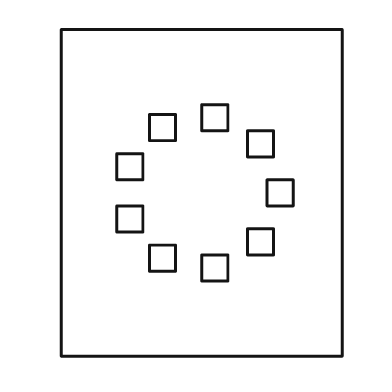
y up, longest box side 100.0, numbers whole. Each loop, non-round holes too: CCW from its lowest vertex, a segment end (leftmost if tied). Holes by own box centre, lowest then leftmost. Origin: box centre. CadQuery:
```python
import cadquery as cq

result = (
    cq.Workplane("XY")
    .moveTo(-43.0, -50.0)
    .lineTo(43.0, -50.0)
    .lineTo(43.0, 50.0)
    .lineTo(-43.0, 50.0)
    .close()
    .moveTo(0.0, -27.0)
    .lineTo(8.0, -27.0)
    .lineTo(8.0, -19.0)
    .lineTo(0.0, -19.0)
    .close()
    .moveTo(-16.0, -24.0)
    .lineTo(-8.0, -24.0)
    .lineTo(-8.0, -16.0)
    .lineTo(-16.0, -16.0)
    .close()
    .moveTo(14.0, -19.0)
    .lineTo(22.0, -19.0)
    .lineTo(22.0, -11.0)
    .lineTo(14.0, -11.0)
    .close()
    .moveTo(-26.0, -12.0)
    .lineTo(-18.0, -12.0)
    .lineTo(-18.0, -4.0)
    .lineTo(-26.0, -4.0)
    .close()
    .moveTo(20.0, -4.0)
    .lineTo(28.0, -4.0)
    .lineTo(28.0, 4.0)
    .lineTo(20.0, 4.0)
    .close()
    .moveTo(-26.0, 4.0)
    .lineTo(-18.0, 4.0)
    .lineTo(-18.0, 12.0)
    .lineTo(-26.0, 12.0)
    .close()
    .moveTo(14.0, 11.0)
    .lineTo(22.0, 11.0)
    .lineTo(22.0, 19.0)
    .lineTo(14.0, 19.0)
    .close()
    .moveTo(-16.0, 16.0)
    .lineTo(-8.0, 16.0)
    .lineTo(-8.0, 24.0)
    .lineTo(-16.0, 24.0)
    .close()
    .moveTo(0.0, 19.0)
    .lineTo(8.0, 19.0)
    .lineTo(8.0, 27.0)
    .lineTo(0.0, 27.0)
    .close()
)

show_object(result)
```